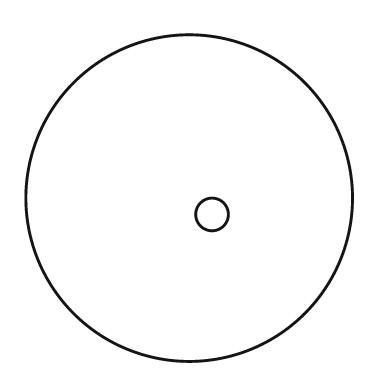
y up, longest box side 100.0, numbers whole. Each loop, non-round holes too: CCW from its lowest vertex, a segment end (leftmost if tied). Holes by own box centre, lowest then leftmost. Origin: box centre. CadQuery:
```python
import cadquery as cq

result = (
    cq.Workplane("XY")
    .moveTo(0.0, 0.0)
    .circle(50.0)
    .moveTo(7.0, -5.0)
    .circle(5.0)
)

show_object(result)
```